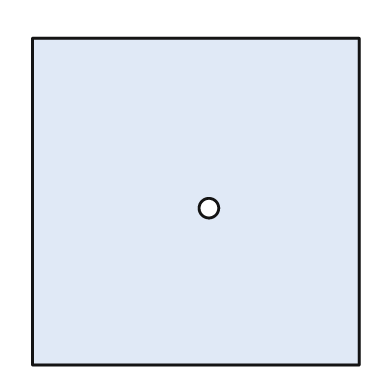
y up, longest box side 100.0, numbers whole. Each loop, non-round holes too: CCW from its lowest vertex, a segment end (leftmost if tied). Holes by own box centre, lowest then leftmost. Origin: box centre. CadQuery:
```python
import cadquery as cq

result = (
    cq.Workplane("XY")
    .moveTo(-50.0, -50.0)
    .lineTo(50.0, -50.0)
    .lineTo(50.0, 50.0)
    .lineTo(-50.0, 50.0)
    .close()
    .moveTo(4.0, -2.0)
    .circle(3.0)
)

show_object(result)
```